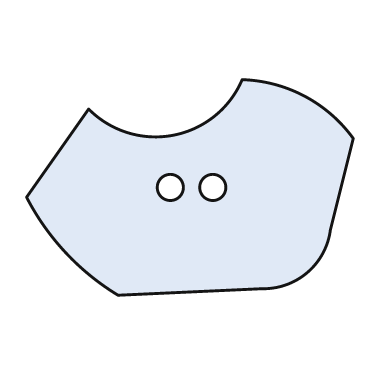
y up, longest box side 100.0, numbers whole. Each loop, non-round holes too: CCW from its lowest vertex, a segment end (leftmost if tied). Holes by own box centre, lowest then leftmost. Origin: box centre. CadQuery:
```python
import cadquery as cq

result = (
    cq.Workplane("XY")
    .moveTo(-22.0, -33.0)
    .lineTo(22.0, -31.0)
    .threePointArc((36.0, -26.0), (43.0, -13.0))
    .lineTo(50.0, 15.0)
    .threePointArc((35.0, 28.0), (16.0, 33.0))
    .threePointArc((-5.0, 16.0), (-31.0, 24.0))
    .lineTo(-50.0, -3.0)
    .threePointArc((-38.0, -20.0), (-22.0, -33.0))
    .close()
    .moveTo(-6.0, 0.0)
    .circle(4.0)
    .moveTo(7.0, 0.0)
    .circle(4.0)
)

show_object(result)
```